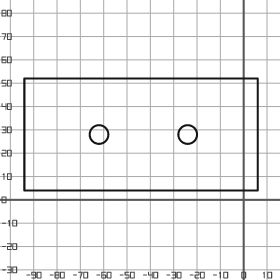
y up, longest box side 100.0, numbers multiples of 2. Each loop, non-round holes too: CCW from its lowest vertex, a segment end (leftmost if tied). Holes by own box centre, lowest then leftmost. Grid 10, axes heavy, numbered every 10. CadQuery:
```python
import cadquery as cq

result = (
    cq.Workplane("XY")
    .moveTo(-94.0, 4.0)
    .lineTo(6.0, 4.0)
    .lineTo(6.0, 52.0)
    .lineTo(-94.0, 52.0)
    .close()
    .moveTo(-62.0, 28.0)
    .circle(4.0)
    .moveTo(-24.0, 28.0)
    .circle(4.0)
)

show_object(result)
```